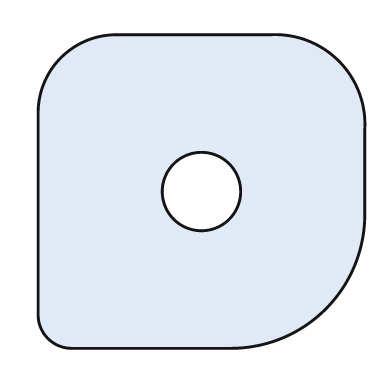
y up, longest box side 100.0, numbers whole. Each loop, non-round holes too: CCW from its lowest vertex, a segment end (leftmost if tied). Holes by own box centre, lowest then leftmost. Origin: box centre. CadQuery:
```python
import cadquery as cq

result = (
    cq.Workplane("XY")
    .moveTo(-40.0, -48.0)
    .lineTo(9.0, -48.0)
    .threePointArc((38.0, -36.0), (50.0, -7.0))
    .lineTo(50.0, 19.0)
    .threePointArc((42.0, 40.0), (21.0, 48.0))
    .lineTo(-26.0, 48.0)
    .threePointArc((-43.0, 41.0), (-50.0, 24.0))
    .lineTo(-50.0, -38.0)
    .threePointArc((-47.0, -45.0), (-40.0, -48.0))
    .close()
    .moveTo(0.0, 0.0)
    .circle(12.0)
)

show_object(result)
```